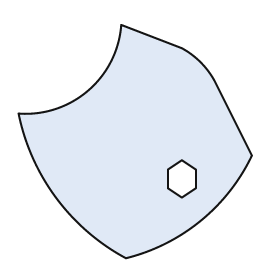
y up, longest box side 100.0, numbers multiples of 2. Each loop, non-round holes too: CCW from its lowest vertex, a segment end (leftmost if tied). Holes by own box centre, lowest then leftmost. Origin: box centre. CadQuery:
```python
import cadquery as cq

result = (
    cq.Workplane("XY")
    .moveTo(-4.0, -50.0)
    .threePointArc((28.0, -34.0), (50.0, -6.0))
    .lineTo(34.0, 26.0)
    .threePointArc((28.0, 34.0), (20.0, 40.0))
    .lineTo(-6.0, 50.0)
    .threePointArc((-20.0, 22.0), (-50.0, 12.0))
    .threePointArc((-34.0, -24.0), (-4.0, -50.0))
    .close()
    .moveTo(20.0, -24.0)
    .lineTo(26.0, -20.0)
    .lineTo(26.0, -12.0)
    .lineTo(20.0, -8.0)
    .lineTo(14.0, -12.0)
    .lineTo(14.0, -20.0)
    .close()
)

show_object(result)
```